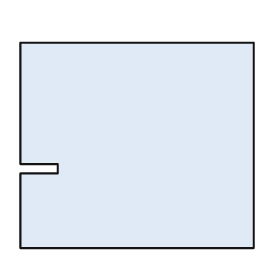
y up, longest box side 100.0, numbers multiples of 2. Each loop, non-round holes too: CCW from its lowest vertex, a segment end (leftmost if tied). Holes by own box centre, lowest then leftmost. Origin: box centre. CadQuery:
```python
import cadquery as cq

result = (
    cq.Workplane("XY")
    .moveTo(-50.0, -44.0)
    .lineTo(50.0, -44.0)
    .lineTo(50.0, 44.0)
    .lineTo(-50.0, 44.0)
    .lineTo(-50.0, -8.0)
    .lineTo(-34.0, -8.0)
    .lineTo(-34.0, -12.0)
    .lineTo(-50.0, -12.0)
    .close()
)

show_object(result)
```